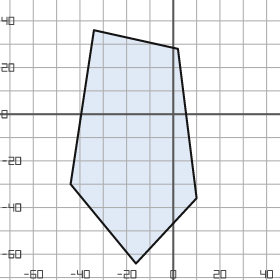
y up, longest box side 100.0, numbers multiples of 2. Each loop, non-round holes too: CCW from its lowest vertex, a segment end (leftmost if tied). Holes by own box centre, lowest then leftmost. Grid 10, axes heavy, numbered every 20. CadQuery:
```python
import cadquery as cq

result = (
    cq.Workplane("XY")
    .moveTo(-16.0, -64.0)
    .lineTo(10.0, -36.0)
    .lineTo(2.0, 28.0)
    .lineTo(-34.0, 36.0)
    .lineTo(-44.0, -30.0)
    .close()
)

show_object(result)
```